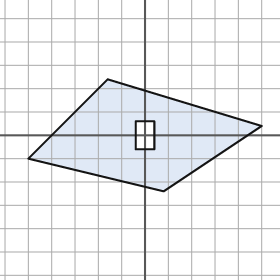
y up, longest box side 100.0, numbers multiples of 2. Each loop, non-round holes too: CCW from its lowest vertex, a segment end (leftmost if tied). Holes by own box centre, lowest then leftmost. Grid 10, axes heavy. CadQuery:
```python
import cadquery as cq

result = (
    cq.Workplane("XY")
    .moveTo(8.0, -24.0)
    .lineTo(50.0, 4.0)
    .lineTo(-16.0, 24.0)
    .lineTo(-50.0, -10.0)
    .close()
    .moveTo(-4.0, -6.0)
    .lineTo(4.0, -6.0)
    .lineTo(4.0, 6.0)
    .lineTo(-4.0, 6.0)
    .close()
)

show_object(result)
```